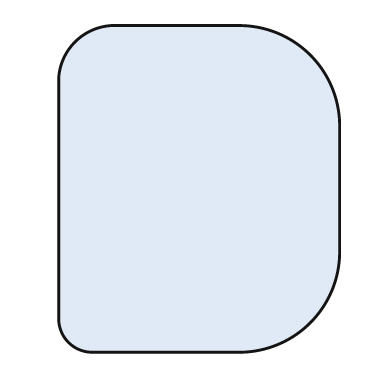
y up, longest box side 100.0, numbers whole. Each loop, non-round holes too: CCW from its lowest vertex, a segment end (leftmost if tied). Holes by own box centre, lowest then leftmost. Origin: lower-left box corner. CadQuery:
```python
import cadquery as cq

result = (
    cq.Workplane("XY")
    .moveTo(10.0, 0.0)
    .lineTo(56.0, 0.0)
    .threePointArc((77.0, 9.0), (86.0, 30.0))
    .lineTo(86.0, 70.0)
    .threePointArc((77.0, 91.0), (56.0, 100.0))
    .lineTo(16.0, 100.0)
    .threePointArc((5.0, 95.0), (0.0, 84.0))
    .lineTo(0.0, 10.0)
    .threePointArc((3.0, 3.0), (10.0, 0.0))
    .close()
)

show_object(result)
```